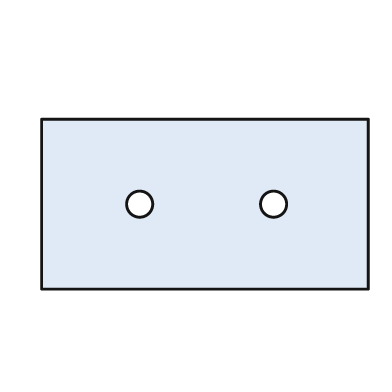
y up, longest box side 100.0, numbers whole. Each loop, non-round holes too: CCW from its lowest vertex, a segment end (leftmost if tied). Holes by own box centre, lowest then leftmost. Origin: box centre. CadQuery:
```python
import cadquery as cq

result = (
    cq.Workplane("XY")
    .moveTo(-50.0, -26.0)
    .lineTo(50.0, -26.0)
    .lineTo(50.0, 26.0)
    .lineTo(-50.0, 26.0)
    .close()
    .moveTo(-20.0, 0.0)
    .circle(4.0)
    .moveTo(21.0, 0.0)
    .circle(4.0)
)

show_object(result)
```